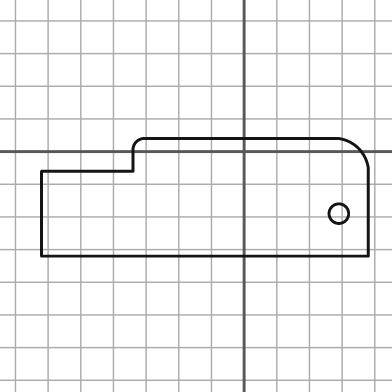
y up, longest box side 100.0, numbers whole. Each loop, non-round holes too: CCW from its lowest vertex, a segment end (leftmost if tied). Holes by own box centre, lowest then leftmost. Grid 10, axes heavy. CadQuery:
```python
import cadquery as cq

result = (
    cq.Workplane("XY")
    .moveTo(-62.0, -32.0)
    .lineTo(38.0, -32.0)
    .lineTo(38.0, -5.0)
    .threePointArc((35.0, 1.0), (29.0, 4.0))
    .lineTo(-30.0, 4.0)
    .threePointArc((-33.0, 3.0), (-34.0, 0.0))
    .lineTo(-34.0, -6.0)
    .lineTo(-62.0, -6.0)
    .close()
    .moveTo(29.0, -19.0)
    .circle(3.0)
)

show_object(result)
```